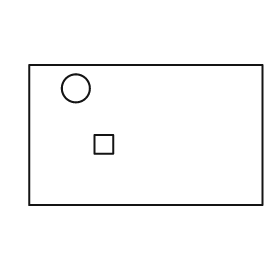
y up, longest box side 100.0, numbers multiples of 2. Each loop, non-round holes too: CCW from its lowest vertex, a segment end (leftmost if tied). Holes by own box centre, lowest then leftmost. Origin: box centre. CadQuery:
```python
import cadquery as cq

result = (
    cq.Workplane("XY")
    .moveTo(-50.0, -30.0)
    .lineTo(50.0, -30.0)
    .lineTo(50.0, 30.0)
    .lineTo(-50.0, 30.0)
    .close()
    .moveTo(-22.0, -8.0)
    .lineTo(-14.0, -8.0)
    .lineTo(-14.0, 0.0)
    .lineTo(-22.0, 0.0)
    .close()
    .moveTo(-30.0, 20.0)
    .circle(6.0)
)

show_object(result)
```